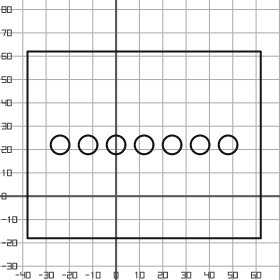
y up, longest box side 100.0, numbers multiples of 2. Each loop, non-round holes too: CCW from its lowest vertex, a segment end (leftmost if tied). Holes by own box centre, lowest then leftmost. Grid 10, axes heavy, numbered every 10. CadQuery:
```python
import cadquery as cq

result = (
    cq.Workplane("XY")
    .moveTo(-38.0, -18.0)
    .lineTo(62.0, -18.0)
    .lineTo(62.0, 62.0)
    .lineTo(-38.0, 62.0)
    .close()
    .moveTo(-24.0, 22.0)
    .circle(4.0)
    .moveTo(-12.0, 22.0)
    .circle(4.0)
    .moveTo(0.0, 22.0)
    .circle(4.0)
    .moveTo(12.0, 22.0)
    .circle(4.0)
    .moveTo(24.0, 22.0)
    .circle(4.0)
    .moveTo(36.0, 22.0)
    .circle(4.0)
    .moveTo(48.0, 22.0)
    .circle(4.0)
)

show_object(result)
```